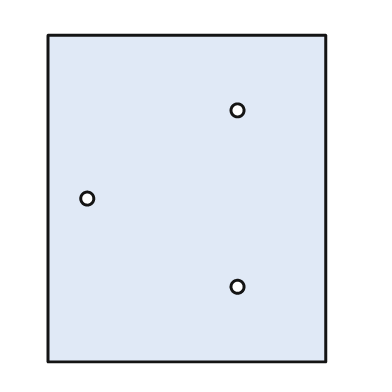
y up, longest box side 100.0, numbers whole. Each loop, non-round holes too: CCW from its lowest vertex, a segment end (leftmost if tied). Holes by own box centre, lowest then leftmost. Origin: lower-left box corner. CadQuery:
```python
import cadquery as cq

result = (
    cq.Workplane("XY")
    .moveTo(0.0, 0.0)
    .lineTo(85.0, 0.0)
    .lineTo(85.0, 100.0)
    .lineTo(0.0, 100.0)
    .close()
    .moveTo(58.0, 23.0)
    .circle(2.0)
    .moveTo(12.0, 50.0)
    .circle(2.0)
    .moveTo(58.0, 77.0)
    .circle(2.0)
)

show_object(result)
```